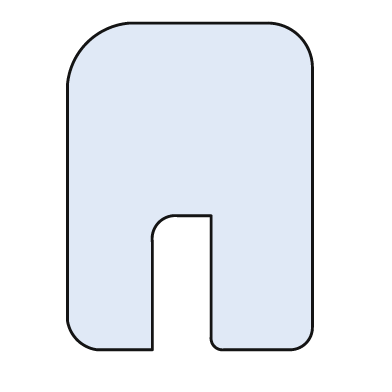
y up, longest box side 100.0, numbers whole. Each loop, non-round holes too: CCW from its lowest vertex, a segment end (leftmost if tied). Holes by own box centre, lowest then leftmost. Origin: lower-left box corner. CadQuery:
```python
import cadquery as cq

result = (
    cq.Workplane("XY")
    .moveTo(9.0, 0.0)
    .lineTo(26.0, 0.0)
    .lineTo(26.0, 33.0)
    .threePointArc((28.0, 39.0), (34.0, 41.0))
    .lineTo(44.0, 41.0)
    .lineTo(44.0, 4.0)
    .threePointArc((45.0, 1.0), (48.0, 0.0))
    .lineTo(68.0, 0.0)
    .threePointArc((73.0, 2.0), (75.0, 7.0))
    .lineTo(75.0, 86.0)
    .threePointArc((71.0, 96.0), (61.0, 100.0))
    .lineTo(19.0, 100.0)
    .threePointArc((6.0, 94.0), (0.0, 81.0))
    .lineTo(0.0, 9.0)
    .threePointArc((3.0, 3.0), (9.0, 0.0))
    .close()
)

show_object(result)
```